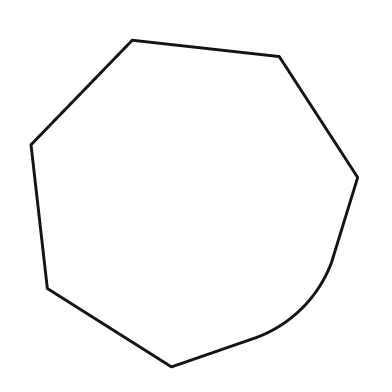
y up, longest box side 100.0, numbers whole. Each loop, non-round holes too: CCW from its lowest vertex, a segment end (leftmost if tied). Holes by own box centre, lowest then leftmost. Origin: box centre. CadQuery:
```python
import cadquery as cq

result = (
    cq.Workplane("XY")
    .moveTo(-7.0, -50.0)
    .lineTo(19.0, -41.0)
    .threePointArc((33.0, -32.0), (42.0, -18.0))
    .lineTo(50.0, 8.0)
    .lineTo(26.0, 45.0)
    .lineTo(-19.0, 50.0)
    .lineTo(-50.0, 18.0)
    .lineTo(-45.0, -26.0)
    .close()
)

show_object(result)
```